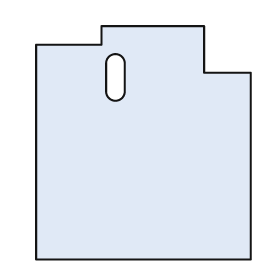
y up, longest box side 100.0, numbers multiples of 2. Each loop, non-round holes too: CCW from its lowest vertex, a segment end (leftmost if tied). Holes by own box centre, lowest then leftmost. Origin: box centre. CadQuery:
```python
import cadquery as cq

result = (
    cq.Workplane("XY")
    .moveTo(-46.0, -50.0)
    .lineTo(46.0, -50.0)
    .lineTo(46.0, 30.0)
    .lineTo(26.0, 30.0)
    .lineTo(26.0, 50.0)
    .lineTo(-18.0, 50.0)
    .lineTo(-18.0, 42.0)
    .lineTo(-46.0, 42.0)
    .close()
    .moveTo(-16.0, 22.0)
    .threePointArc((-12.0, 18.0), (-8.0, 22.0))
    .lineTo(-8.0, 34.0)
    .threePointArc((-12.0, 38.0), (-16.0, 34.0))
    .close()
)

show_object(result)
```